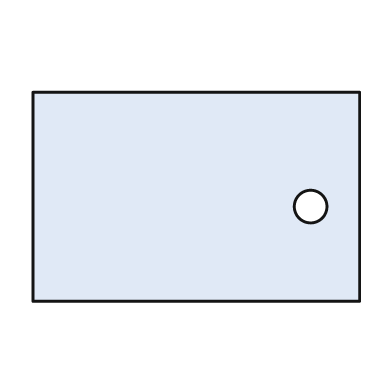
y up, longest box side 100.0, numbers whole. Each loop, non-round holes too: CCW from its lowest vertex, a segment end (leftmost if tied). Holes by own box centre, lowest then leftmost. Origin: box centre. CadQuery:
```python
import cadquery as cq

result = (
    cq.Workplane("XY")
    .moveTo(-50.0, -32.0)
    .lineTo(50.0, -32.0)
    .lineTo(50.0, 32.0)
    .lineTo(-50.0, 32.0)
    .close()
    .moveTo(35.0, -3.0)
    .circle(5.0)
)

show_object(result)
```